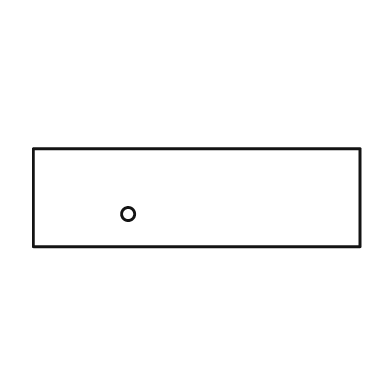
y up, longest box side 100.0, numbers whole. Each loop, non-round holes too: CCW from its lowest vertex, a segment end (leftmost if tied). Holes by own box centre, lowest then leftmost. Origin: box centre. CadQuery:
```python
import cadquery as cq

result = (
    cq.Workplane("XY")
    .moveTo(-50.0, -15.0)
    .lineTo(50.0, -15.0)
    .lineTo(50.0, 15.0)
    .lineTo(-50.0, 15.0)
    .close()
    .moveTo(-21.0, -5.0)
    .circle(2.0)
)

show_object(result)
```